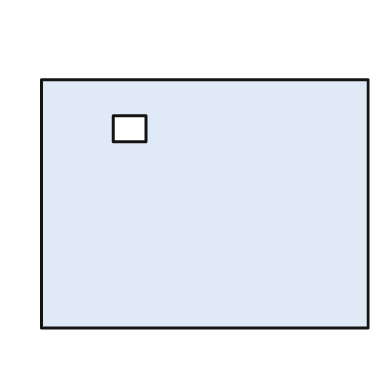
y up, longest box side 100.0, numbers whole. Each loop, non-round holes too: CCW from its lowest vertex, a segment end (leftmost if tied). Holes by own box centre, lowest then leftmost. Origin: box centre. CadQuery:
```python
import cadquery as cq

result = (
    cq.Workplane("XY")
    .moveTo(-50.0, -38.0)
    .lineTo(50.0, -38.0)
    .lineTo(50.0, 38.0)
    .lineTo(-50.0, 38.0)
    .close()
    .moveTo(-28.0, 19.0)
    .lineTo(-18.0, 19.0)
    .lineTo(-18.0, 27.0)
    .lineTo(-28.0, 27.0)
    .close()
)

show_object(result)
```